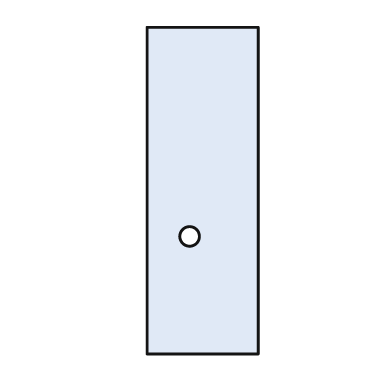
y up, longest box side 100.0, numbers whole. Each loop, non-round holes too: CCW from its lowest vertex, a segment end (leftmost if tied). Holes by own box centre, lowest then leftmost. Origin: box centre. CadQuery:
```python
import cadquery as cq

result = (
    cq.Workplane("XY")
    .moveTo(-17.0, -50.0)
    .lineTo(17.0, -50.0)
    .lineTo(17.0, 50.0)
    .lineTo(-17.0, 50.0)
    .close()
    .moveTo(-4.0, -14.0)
    .circle(3.0)
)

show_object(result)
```